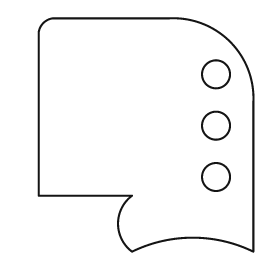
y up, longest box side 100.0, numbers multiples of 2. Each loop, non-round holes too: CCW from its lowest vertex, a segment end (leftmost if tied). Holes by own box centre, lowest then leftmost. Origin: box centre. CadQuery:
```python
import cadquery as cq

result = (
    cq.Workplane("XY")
    .moveTo(-6.0, -50.0)
    .threePointArc((20.0, -44.0), (46.0, -50.0))
    .lineTo(46.0, 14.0)
    .threePointArc((36.0, 40.0), (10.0, 50.0))
    .lineTo(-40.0, 50.0)
    .threePointArc((-44.0, 48.0), (-46.0, 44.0))
    .lineTo(-46.0, -26.0)
    .lineTo(-6.0, -26.0)
    .threePointArc((-12.0, -38.0), (-6.0, -50.0))
    .close()
    .moveTo(30.0, -18.0)
    .circle(6.0)
    .moveTo(30.0, 4.0)
    .circle(6.0)
    .moveTo(30.0, 26.0)
    .circle(6.0)
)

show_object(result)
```